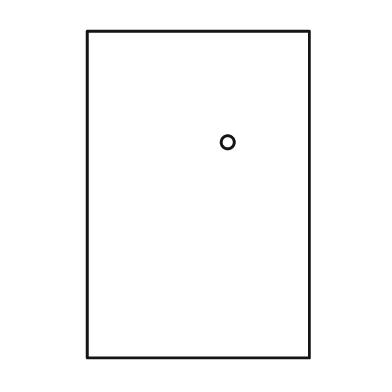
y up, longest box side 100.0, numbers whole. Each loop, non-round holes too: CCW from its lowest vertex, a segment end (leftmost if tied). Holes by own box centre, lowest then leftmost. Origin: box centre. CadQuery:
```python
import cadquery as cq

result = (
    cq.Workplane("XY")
    .moveTo(-34.0, -50.0)
    .lineTo(34.0, -50.0)
    .lineTo(34.0, 50.0)
    .lineTo(-34.0, 50.0)
    .close()
    .moveTo(9.0, 16.0)
    .circle(2.0)
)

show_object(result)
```